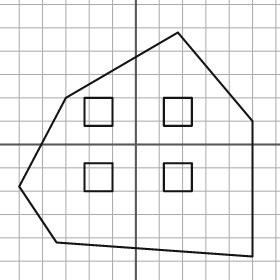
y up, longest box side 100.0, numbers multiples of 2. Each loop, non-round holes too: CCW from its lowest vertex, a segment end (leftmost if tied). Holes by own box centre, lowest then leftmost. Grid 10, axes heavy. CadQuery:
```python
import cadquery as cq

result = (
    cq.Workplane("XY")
    .moveTo(50.0, -48.0)
    .lineTo(50.0, 10.0)
    .lineTo(18.0, 48.0)
    .lineTo(-30.0, 20.0)
    .lineTo(-50.0, -18.0)
    .lineTo(-34.0, -42.0)
    .close()
    .moveTo(-22.0, -20.0)
    .lineTo(-10.0, -20.0)
    .lineTo(-10.0, -8.0)
    .lineTo(-22.0, -8.0)
    .close()
    .moveTo(12.0, -20.0)
    .lineTo(24.0, -20.0)
    .lineTo(24.0, -8.0)
    .lineTo(12.0, -8.0)
    .close()
    .moveTo(-22.0, 8.0)
    .lineTo(-10.0, 8.0)
    .lineTo(-10.0, 20.0)
    .lineTo(-22.0, 20.0)
    .close()
    .moveTo(12.0, 8.0)
    .lineTo(24.0, 8.0)
    .lineTo(24.0, 20.0)
    .lineTo(12.0, 20.0)
    .close()
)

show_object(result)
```